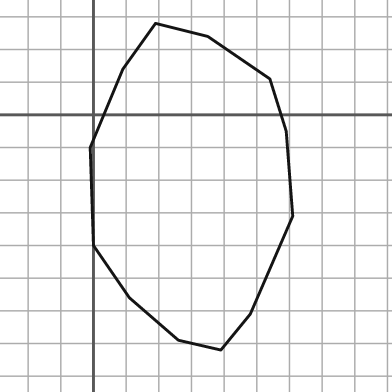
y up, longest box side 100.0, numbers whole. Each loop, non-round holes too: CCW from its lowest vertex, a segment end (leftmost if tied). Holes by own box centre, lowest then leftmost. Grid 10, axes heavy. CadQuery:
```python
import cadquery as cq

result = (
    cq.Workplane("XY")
    .moveTo(39.0, -72.0)
    .lineTo(48.0, -61.0)
    .lineTo(61.0, -31.0)
    .lineTo(59.0, -5.0)
    .lineTo(54.0, 11.0)
    .lineTo(35.0, 24.0)
    .lineTo(19.0, 28.0)
    .lineTo(9.0, 14.0)
    .lineTo(-1.0, -10.0)
    .lineTo(0.0, -40.0)
    .lineTo(11.0, -56.0)
    .lineTo(26.0, -69.0)
    .close()
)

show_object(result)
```